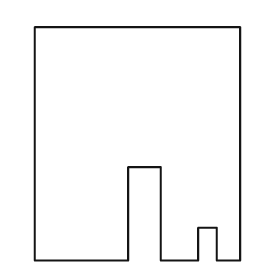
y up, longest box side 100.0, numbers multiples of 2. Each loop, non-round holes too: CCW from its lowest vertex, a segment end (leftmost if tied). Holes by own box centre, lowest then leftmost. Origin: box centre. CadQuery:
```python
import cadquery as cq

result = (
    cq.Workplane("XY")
    .moveTo(-44.0, -50.0)
    .lineTo(-4.0, -50.0)
    .lineTo(-4.0, -10.0)
    .lineTo(10.0, -10.0)
    .lineTo(10.0, -50.0)
    .lineTo(26.0, -50.0)
    .lineTo(26.0, -36.0)
    .lineTo(34.0, -36.0)
    .lineTo(34.0, -50.0)
    .lineTo(44.0, -50.0)
    .lineTo(44.0, 50.0)
    .lineTo(-44.0, 50.0)
    .close()
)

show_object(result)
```